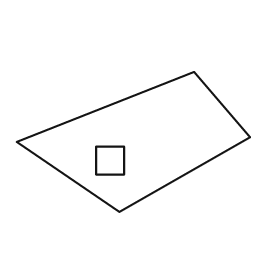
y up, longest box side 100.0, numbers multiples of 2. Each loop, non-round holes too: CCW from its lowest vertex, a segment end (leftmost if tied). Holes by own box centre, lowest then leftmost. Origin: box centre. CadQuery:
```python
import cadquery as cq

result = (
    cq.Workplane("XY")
    .moveTo(-6.0, -30.0)
    .lineTo(50.0, 2.0)
    .lineTo(26.0, 30.0)
    .lineTo(-50.0, 0.0)
    .close()
    .moveTo(-16.0, -14.0)
    .lineTo(-4.0, -14.0)
    .lineTo(-4.0, -2.0)
    .lineTo(-16.0, -2.0)
    .close()
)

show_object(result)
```